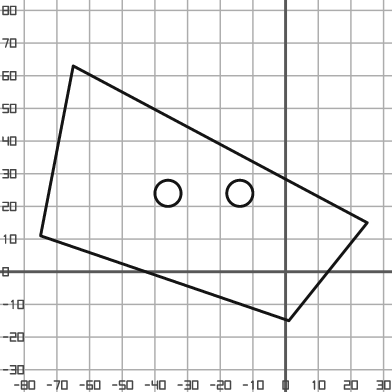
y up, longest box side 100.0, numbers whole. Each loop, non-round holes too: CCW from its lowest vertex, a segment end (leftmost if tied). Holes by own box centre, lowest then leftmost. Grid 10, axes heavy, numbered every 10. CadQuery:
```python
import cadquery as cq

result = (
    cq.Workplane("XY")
    .moveTo(1.0, -15.0)
    .lineTo(25.0, 15.0)
    .lineTo(-65.0, 63.0)
    .lineTo(-75.0, 11.0)
    .close()
    .moveTo(-36.0, 24.0)
    .circle(4.0)
    .moveTo(-14.0, 24.0)
    .circle(4.0)
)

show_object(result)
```